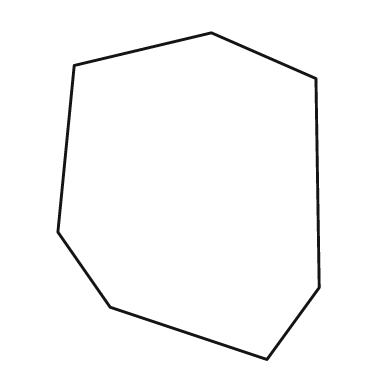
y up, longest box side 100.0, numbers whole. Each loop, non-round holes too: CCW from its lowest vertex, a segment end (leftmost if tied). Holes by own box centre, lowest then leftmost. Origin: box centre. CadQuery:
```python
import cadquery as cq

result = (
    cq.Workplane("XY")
    .moveTo(24.0, -50.0)
    .lineTo(40.0, -28.0)
    .lineTo(39.0, 36.0)
    .lineTo(7.0, 50.0)
    .lineTo(-35.0, 40.0)
    .lineTo(-40.0, -11.0)
    .lineTo(-24.0, -34.0)
    .close()
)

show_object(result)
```